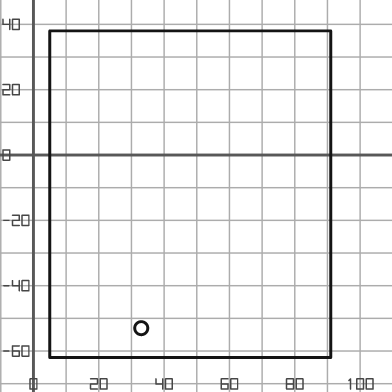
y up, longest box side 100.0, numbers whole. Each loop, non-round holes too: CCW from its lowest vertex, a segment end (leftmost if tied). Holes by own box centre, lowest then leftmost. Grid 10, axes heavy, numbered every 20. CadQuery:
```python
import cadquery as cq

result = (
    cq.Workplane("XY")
    .moveTo(5.0, -62.0)
    .lineTo(91.0, -62.0)
    .lineTo(91.0, 38.0)
    .lineTo(5.0, 38.0)
    .close()
    .moveTo(33.0, -53.0)
    .circle(2.0)
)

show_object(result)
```